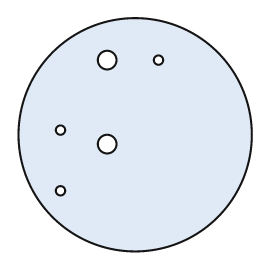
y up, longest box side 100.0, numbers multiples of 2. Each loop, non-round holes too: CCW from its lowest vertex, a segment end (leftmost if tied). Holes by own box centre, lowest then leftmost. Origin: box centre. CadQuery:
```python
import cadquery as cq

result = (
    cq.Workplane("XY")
    .moveTo(0.0, 0.0)
    .circle(50.0)
    .moveTo(-32.0, -24.0)
    .circle(2.0)
    .moveTo(-12.0, -4.0)
    .circle(4.0)
    .moveTo(-32.0, 2.0)
    .circle(2.0)
    .moveTo(-12.0, 32.0)
    .circle(4.0)
    .moveTo(10.0, 32.0)
    .circle(2.0)
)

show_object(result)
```